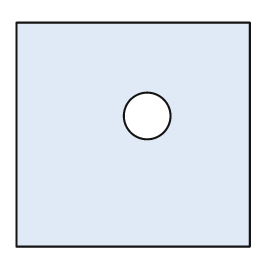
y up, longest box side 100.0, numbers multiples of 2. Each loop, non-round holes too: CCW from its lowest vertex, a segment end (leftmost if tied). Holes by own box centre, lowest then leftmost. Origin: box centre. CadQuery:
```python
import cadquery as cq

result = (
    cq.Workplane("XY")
    .moveTo(-50.0, -48.0)
    .lineTo(50.0, -48.0)
    .lineTo(50.0, 48.0)
    .lineTo(-50.0, 48.0)
    .close()
    .moveTo(6.0, 8.0)
    .circle(10.0)
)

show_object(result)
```